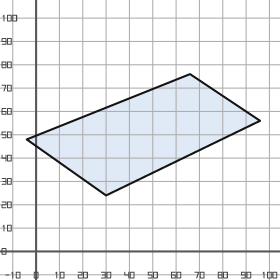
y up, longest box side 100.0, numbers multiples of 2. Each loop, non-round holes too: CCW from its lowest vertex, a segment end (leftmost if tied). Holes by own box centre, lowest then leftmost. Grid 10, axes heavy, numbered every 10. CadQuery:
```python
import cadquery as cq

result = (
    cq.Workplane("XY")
    .moveTo(30.0, 24.0)
    .lineTo(96.0, 56.0)
    .lineTo(66.0, 76.0)
    .lineTo(-4.0, 48.0)
    .close()
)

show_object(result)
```